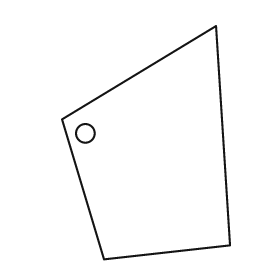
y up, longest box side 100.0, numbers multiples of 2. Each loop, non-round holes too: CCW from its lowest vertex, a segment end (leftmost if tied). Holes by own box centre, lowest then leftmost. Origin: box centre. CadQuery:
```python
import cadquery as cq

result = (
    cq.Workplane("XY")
    .moveTo(-18.0, -50.0)
    .lineTo(36.0, -44.0)
    .lineTo(30.0, 50.0)
    .lineTo(-36.0, 10.0)
    .close()
    .moveTo(-26.0, 4.0)
    .circle(4.0)
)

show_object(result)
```